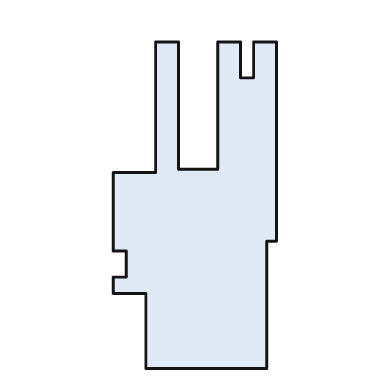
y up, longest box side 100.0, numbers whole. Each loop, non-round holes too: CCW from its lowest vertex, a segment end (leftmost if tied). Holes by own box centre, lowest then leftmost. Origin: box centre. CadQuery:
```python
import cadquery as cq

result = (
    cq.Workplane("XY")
    .moveTo(-15.0, -50.0)
    .lineTo(22.0, -50.0)
    .lineTo(22.0, -11.0)
    .lineTo(25.0, -11.0)
    .lineTo(25.0, 50.0)
    .lineTo(18.0, 50.0)
    .lineTo(18.0, 39.0)
    .lineTo(14.0, 39.0)
    .lineTo(14.0, 50.0)
    .lineTo(7.0, 50.0)
    .lineTo(7.0, 11.0)
    .lineTo(-5.0, 11.0)
    .lineTo(-5.0, 50.0)
    .lineTo(-12.0, 50.0)
    .lineTo(-12.0, 10.0)
    .lineTo(-25.0, 10.0)
    .lineTo(-25.0, -14.0)
    .lineTo(-21.0, -14.0)
    .lineTo(-21.0, -22.0)
    .lineTo(-25.0, -22.0)
    .lineTo(-25.0, -27.0)
    .lineTo(-15.0, -27.0)
    .close()
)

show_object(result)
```